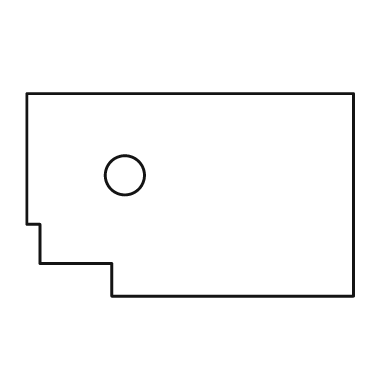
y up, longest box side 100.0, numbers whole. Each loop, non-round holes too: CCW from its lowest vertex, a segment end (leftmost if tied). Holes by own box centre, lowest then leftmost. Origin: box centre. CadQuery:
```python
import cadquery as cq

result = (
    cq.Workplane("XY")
    .moveTo(-24.0, -31.0)
    .lineTo(50.0, -31.0)
    .lineTo(50.0, 31.0)
    .lineTo(-50.0, 31.0)
    .lineTo(-50.0, -9.0)
    .lineTo(-46.0, -9.0)
    .lineTo(-46.0, -21.0)
    .lineTo(-24.0, -21.0)
    .close()
    .moveTo(-20.0, 6.0)
    .circle(6.0)
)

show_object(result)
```